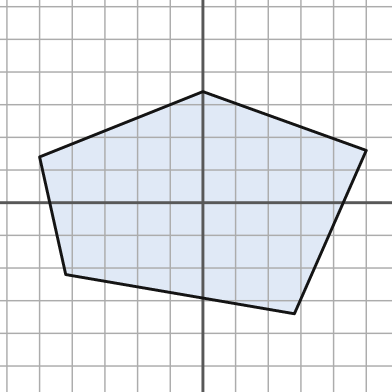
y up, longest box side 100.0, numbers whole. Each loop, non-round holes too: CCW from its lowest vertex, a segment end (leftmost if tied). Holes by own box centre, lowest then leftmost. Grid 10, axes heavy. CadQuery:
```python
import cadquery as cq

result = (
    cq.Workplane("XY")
    .moveTo(28.0, -34.0)
    .lineTo(50.0, 16.0)
    .lineTo(0.0, 34.0)
    .lineTo(-50.0, 14.0)
    .lineTo(-42.0, -22.0)
    .close()
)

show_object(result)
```